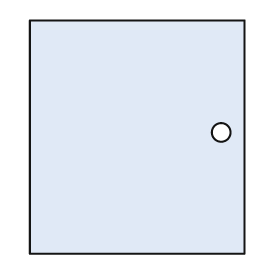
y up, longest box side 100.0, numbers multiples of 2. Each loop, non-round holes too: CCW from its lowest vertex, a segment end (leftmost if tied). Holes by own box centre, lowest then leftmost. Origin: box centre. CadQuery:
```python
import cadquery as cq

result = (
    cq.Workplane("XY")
    .moveTo(-46.0, -50.0)
    .lineTo(46.0, -50.0)
    .lineTo(46.0, 50.0)
    .lineTo(-46.0, 50.0)
    .close()
    .moveTo(36.0, 2.0)
    .circle(4.0)
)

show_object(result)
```